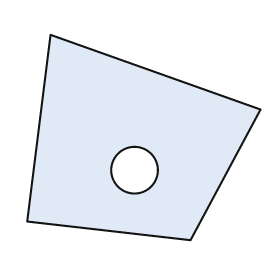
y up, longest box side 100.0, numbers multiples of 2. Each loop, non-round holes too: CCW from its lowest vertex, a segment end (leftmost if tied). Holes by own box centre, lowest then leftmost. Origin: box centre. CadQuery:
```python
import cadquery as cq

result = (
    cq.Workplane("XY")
    .moveTo(20.0, -44.0)
    .lineTo(50.0, 12.0)
    .lineTo(-40.0, 44.0)
    .lineTo(-50.0, -36.0)
    .close()
    .moveTo(-4.0, -14.0)
    .circle(10.0)
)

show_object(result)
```